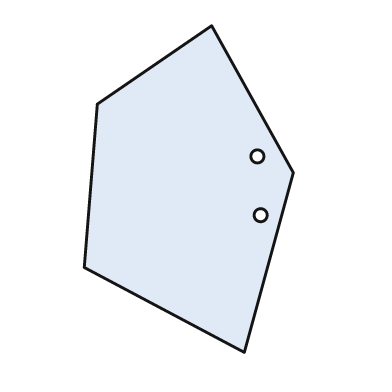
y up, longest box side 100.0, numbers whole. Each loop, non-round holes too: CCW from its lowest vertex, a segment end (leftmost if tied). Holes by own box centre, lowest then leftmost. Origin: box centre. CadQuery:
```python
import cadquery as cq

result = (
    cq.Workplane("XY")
    .moveTo(17.0, -50.0)
    .lineTo(32.0, 5.0)
    .lineTo(7.0, 50.0)
    .lineTo(-28.0, 26.0)
    .lineTo(-32.0, -24.0)
    .close()
    .moveTo(22.0, -8.0)
    .circle(2.0)
    .moveTo(21.0, 10.0)
    .circle(2.0)
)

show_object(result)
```